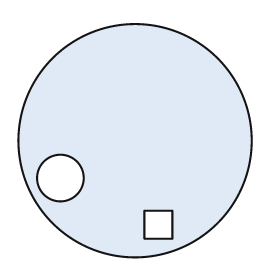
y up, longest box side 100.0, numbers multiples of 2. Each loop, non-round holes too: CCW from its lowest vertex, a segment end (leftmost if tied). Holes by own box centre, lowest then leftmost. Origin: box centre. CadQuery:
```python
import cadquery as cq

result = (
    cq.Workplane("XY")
    .moveTo(0.0, 0.0)
    .circle(50.0)
    .moveTo(4.0, -42.0)
    .lineTo(16.0, -42.0)
    .lineTo(16.0, -30.0)
    .lineTo(4.0, -30.0)
    .close()
    .moveTo(-32.0, -16.0)
    .circle(10.0)
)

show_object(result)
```